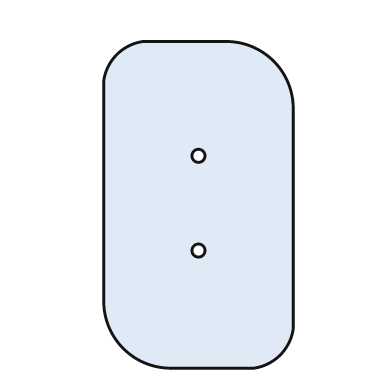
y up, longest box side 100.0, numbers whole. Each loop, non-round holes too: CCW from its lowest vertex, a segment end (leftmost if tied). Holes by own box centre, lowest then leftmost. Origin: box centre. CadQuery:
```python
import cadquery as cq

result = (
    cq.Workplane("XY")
    .moveTo(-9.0, -50.0)
    .lineTo(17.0, -50.0)
    .threePointArc((25.0, -46.0), (29.0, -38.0))
    .lineTo(29.0, 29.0)
    .threePointArc((23.0, 44.0), (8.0, 50.0))
    .lineTo(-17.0, 50.0)
    .threePointArc((-25.0, 46.0), (-29.0, 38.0))
    .lineTo(-29.0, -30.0)
    .threePointArc((-23.0, -44.0), (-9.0, -50.0))
    .close()
    .moveTo(0.0, -14.0)
    .circle(2.0)
    .moveTo(0.0, 15.0)
    .circle(2.0)
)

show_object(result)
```